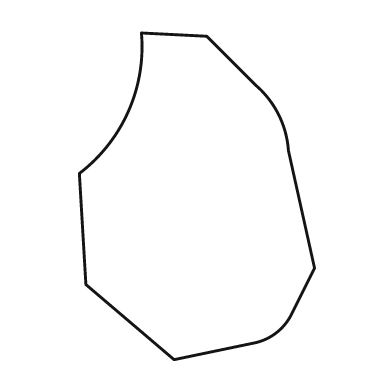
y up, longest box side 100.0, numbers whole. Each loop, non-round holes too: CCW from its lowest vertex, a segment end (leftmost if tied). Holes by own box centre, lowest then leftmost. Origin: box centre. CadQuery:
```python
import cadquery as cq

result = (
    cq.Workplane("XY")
    .moveTo(-7.0, -50.0)
    .lineTo(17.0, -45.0)
    .threePointArc((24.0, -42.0), (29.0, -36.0))
    .lineTo(36.0, -22.0)
    .lineTo(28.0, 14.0)
    .threePointArc((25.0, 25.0), (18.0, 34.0))
    .lineTo(3.0, 49.0)
    .lineTo(-17.0, 50.0)
    .threePointArc((-21.0, 26.0), (-36.0, 7.0))
    .lineTo(-34.0, -27.0)
    .close()
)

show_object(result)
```